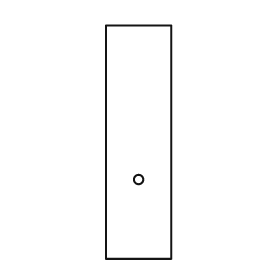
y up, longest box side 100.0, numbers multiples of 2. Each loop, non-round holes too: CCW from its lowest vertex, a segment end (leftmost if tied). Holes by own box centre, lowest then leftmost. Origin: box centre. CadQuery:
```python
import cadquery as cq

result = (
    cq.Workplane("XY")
    .moveTo(-14.0, -50.0)
    .lineTo(14.0, -50.0)
    .lineTo(14.0, 50.0)
    .lineTo(-14.0, 50.0)
    .close()
    .moveTo(0.0, -16.0)
    .circle(2.0)
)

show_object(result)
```